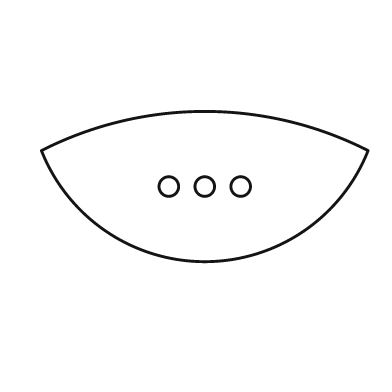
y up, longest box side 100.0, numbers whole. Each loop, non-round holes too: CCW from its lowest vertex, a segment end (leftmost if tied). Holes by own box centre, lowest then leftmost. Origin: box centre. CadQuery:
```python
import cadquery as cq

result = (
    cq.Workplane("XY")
    .moveTo(-50.0, 11.0)
    .threePointArc((0.0, -23.0), (50.0, 11.0))
    .threePointArc((0.0, 23.0), (-50.0, 11.0))
    .close()
    .moveTo(-11.0, 0.0)
    .circle(3.0)
    .moveTo(0.0, 0.0)
    .circle(3.0)
    .moveTo(11.0, 0.0)
    .circle(3.0)
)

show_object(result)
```